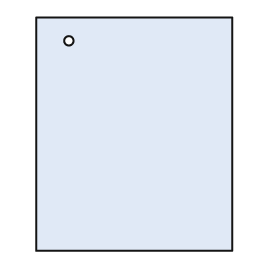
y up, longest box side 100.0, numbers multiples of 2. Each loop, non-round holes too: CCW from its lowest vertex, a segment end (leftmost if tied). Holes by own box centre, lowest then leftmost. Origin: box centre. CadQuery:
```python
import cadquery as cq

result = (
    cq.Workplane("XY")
    .moveTo(-42.0, -50.0)
    .lineTo(42.0, -50.0)
    .lineTo(42.0, 50.0)
    .lineTo(-42.0, 50.0)
    .close()
    .moveTo(-28.0, 40.0)
    .circle(2.0)
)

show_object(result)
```